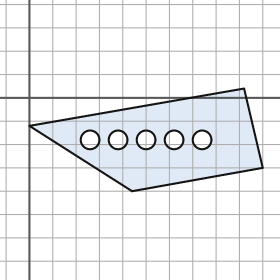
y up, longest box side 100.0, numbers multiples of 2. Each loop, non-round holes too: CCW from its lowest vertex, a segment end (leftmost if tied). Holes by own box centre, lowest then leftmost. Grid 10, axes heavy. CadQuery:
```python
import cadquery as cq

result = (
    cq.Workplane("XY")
    .moveTo(44.0, -40.0)
    .lineTo(100.0, -30.0)
    .lineTo(92.0, 4.0)
    .lineTo(0.0, -12.0)
    .close()
    .moveTo(26.0, -18.0)
    .circle(4.0)
    .moveTo(38.0, -18.0)
    .circle(4.0)
    .moveTo(50.0, -18.0)
    .circle(4.0)
    .moveTo(62.0, -18.0)
    .circle(4.0)
    .moveTo(74.0, -18.0)
    .circle(4.0)
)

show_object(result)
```